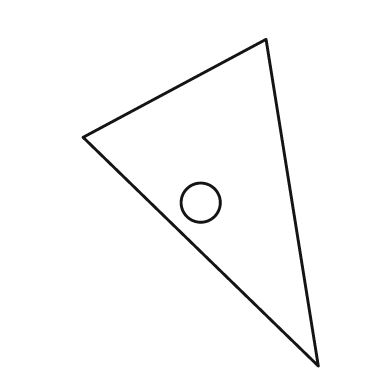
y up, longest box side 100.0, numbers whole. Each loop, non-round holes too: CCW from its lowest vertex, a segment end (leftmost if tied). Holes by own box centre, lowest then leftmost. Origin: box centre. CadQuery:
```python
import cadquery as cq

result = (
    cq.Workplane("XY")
    .moveTo(36.0, -50.0)
    .lineTo(20.0, 50.0)
    .lineTo(-36.0, 20.0)
    .close()
    .moveTo(0.0, 0.0)
    .circle(6.0)
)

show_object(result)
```